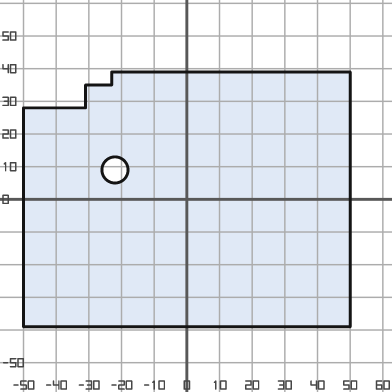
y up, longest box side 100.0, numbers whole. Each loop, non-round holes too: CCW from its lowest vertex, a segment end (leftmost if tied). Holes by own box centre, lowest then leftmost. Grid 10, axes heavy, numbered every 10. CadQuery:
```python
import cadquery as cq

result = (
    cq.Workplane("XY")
    .moveTo(-50.0, -39.0)
    .lineTo(50.0, -39.0)
    .lineTo(50.0, 39.0)
    .lineTo(-23.0, 39.0)
    .lineTo(-23.0, 35.0)
    .lineTo(-31.0, 35.0)
    .lineTo(-31.0, 28.0)
    .lineTo(-50.0, 28.0)
    .close()
    .moveTo(-22.0, 9.0)
    .circle(4.0)
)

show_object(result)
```